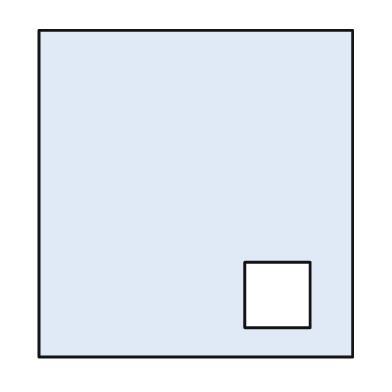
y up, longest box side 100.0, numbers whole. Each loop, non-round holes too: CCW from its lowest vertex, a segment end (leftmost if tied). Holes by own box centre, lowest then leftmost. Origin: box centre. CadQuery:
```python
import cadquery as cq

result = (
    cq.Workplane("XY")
    .moveTo(-48.0, -50.0)
    .lineTo(48.0, -50.0)
    .lineTo(48.0, 50.0)
    .lineTo(-48.0, 50.0)
    .close()
    .moveTo(15.0, -41.0)
    .lineTo(35.0, -41.0)
    .lineTo(35.0, -21.0)
    .lineTo(15.0, -21.0)
    .close()
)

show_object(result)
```